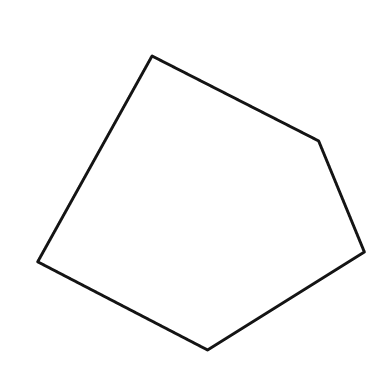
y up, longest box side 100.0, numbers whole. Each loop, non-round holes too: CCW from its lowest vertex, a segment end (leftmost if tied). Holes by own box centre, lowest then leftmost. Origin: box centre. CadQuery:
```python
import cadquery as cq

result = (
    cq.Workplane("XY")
    .moveTo(2.0, -45.0)
    .lineTo(50.0, -15.0)
    .lineTo(36.0, 19.0)
    .lineTo(-15.0, 45.0)
    .lineTo(-50.0, -18.0)
    .close()
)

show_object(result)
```